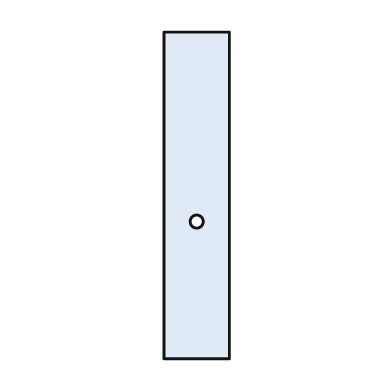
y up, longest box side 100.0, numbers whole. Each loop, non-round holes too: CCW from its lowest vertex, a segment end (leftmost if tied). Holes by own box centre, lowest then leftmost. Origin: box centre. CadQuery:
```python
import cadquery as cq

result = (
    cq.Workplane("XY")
    .moveTo(-10.0, -50.0)
    .lineTo(10.0, -50.0)
    .lineTo(10.0, 50.0)
    .lineTo(-10.0, 50.0)
    .close()
    .moveTo(0.0, -8.0)
    .circle(2.0)
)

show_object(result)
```